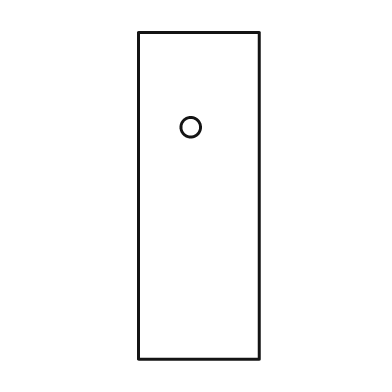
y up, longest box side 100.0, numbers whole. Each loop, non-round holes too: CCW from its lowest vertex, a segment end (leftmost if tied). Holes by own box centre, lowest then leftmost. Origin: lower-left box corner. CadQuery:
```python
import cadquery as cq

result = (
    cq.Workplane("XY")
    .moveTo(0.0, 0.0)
    .lineTo(37.0, 0.0)
    .lineTo(37.0, 100.0)
    .lineTo(0.0, 100.0)
    .close()
    .moveTo(16.0, 71.0)
    .circle(3.0)
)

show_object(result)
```